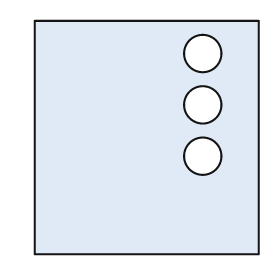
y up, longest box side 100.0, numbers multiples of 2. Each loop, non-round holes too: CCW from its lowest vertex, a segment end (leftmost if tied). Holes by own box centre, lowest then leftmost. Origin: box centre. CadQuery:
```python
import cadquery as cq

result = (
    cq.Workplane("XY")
    .moveTo(-48.0, -50.0)
    .lineTo(48.0, -50.0)
    .lineTo(48.0, 50.0)
    .lineTo(-48.0, 50.0)
    .close()
    .moveTo(24.0, -8.0)
    .circle(8.0)
    .moveTo(24.0, 14.0)
    .circle(8.0)
    .moveTo(24.0, 36.0)
    .circle(8.0)
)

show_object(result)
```